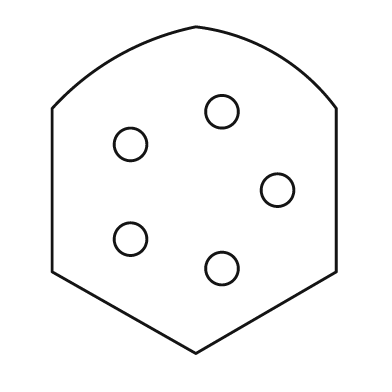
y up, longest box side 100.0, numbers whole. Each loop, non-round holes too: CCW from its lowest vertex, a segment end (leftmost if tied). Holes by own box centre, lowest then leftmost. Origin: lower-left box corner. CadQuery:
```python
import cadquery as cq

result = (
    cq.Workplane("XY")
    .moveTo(44.0, 0.0)
    .lineTo(87.0, 25.0)
    .lineTo(87.0, 75.0)
    .threePointArc((68.0, 92.0), (44.0, 100.0))
    .threePointArc((20.0, 91.0), (0.0, 75.0))
    .lineTo(0.0, 25.0)
    .close()
    .moveTo(52.0, 26.0)
    .circle(5.0)
    .moveTo(24.0, 35.0)
    .circle(5.0)
    .moveTo(69.0, 50.0)
    .circle(5.0)
    .moveTo(24.0, 64.0)
    .circle(5.0)
    .moveTo(52.0, 74.0)
    .circle(5.0)
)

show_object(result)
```